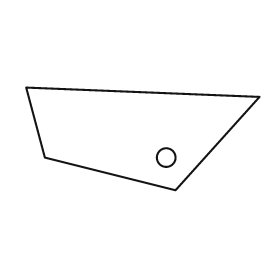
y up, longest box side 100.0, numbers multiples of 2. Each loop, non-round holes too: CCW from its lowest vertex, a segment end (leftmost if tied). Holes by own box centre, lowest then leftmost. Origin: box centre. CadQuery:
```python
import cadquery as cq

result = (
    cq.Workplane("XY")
    .moveTo(14.0, -22.0)
    .lineTo(50.0, 18.0)
    .lineTo(-50.0, 22.0)
    .lineTo(-42.0, -8.0)
    .close()
    .moveTo(10.0, -8.0)
    .circle(4.0)
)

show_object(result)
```